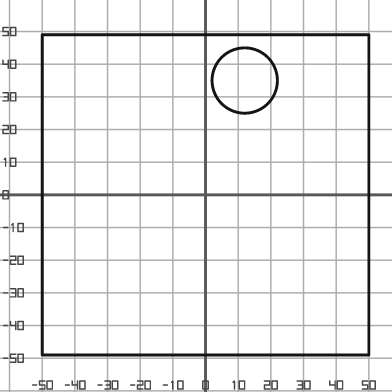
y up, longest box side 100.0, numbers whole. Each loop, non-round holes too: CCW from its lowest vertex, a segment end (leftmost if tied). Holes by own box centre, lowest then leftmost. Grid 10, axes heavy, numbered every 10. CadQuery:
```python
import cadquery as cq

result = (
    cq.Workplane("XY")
    .moveTo(-50.0, -49.0)
    .lineTo(50.0, -49.0)
    .lineTo(50.0, 49.0)
    .lineTo(-50.0, 49.0)
    .close()
    .moveTo(12.0, 35.0)
    .circle(10.0)
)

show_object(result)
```